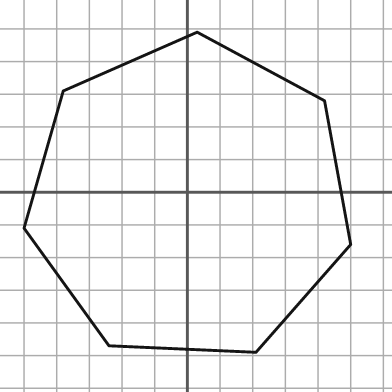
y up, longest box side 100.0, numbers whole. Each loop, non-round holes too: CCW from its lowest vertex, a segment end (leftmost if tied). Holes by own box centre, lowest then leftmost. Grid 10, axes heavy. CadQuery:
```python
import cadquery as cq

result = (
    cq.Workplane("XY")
    .moveTo(21.0, -49.0)
    .lineTo(50.0, -16.0)
    .lineTo(42.0, 28.0)
    .lineTo(3.0, 49.0)
    .lineTo(-38.0, 31.0)
    .lineTo(-50.0, -11.0)
    .lineTo(-24.0, -47.0)
    .close()
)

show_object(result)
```